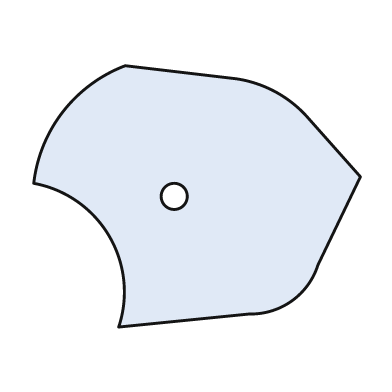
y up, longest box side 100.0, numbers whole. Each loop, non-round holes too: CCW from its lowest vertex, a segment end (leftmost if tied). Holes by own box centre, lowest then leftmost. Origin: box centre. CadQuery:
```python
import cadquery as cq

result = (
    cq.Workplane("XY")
    .moveTo(-24.0, -40.0)
    .lineTo(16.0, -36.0)
    .threePointArc((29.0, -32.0), (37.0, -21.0))
    .lineTo(50.0, 6.0)
    .lineTo(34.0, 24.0)
    .threePointArc((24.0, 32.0), (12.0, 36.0))
    .lineTo(-22.0, 40.0)
    .threePointArc((-41.0, 26.0), (-50.0, 4.0))
    .threePointArc((-27.0, -12.0), (-24.0, -40.0))
    .close()
    .moveTo(-7.0, 0.0)
    .circle(4.0)
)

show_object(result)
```